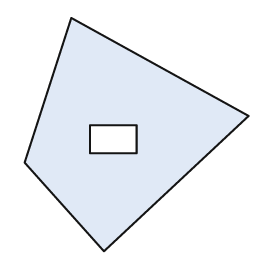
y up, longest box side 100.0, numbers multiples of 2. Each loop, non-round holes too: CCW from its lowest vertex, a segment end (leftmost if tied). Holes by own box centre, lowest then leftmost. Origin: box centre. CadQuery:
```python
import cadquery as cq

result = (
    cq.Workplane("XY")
    .moveTo(-14.0, -50.0)
    .lineTo(48.0, 8.0)
    .lineTo(-28.0, 50.0)
    .lineTo(-48.0, -12.0)
    .close()
    .moveTo(-20.0, -8.0)
    .lineTo(0.0, -8.0)
    .lineTo(0.0, 4.0)
    .lineTo(-20.0, 4.0)
    .close()
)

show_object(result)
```